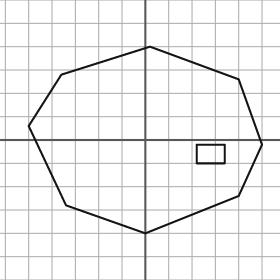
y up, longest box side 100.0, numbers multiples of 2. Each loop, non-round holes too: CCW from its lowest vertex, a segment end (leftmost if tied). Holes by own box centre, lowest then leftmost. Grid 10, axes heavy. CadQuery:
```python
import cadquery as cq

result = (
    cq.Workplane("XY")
    .moveTo(0.0, -40.0)
    .lineTo(40.0, -24.0)
    .lineTo(50.0, -2.0)
    .lineTo(40.0, 26.0)
    .lineTo(2.0, 40.0)
    .lineTo(-36.0, 28.0)
    .lineTo(-50.0, 6.0)
    .lineTo(-34.0, -28.0)
    .close()
    .moveTo(22.0, -10.0)
    .lineTo(34.0, -10.0)
    .lineTo(34.0, -2.0)
    .lineTo(22.0, -2.0)
    .close()
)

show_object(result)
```